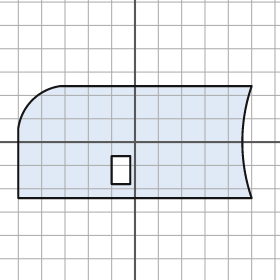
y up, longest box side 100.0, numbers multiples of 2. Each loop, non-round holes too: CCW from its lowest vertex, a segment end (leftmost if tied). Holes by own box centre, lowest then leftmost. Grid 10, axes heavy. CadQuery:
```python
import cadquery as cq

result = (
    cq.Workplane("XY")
    .moveTo(-50.0, -24.0)
    .lineTo(50.0, -24.0)
    .threePointArc((46.0, 0.0), (50.0, 24.0))
    .lineTo(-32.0, 24.0)
    .threePointArc((-44.0, 18.0), (-50.0, 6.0))
    .close()
    .moveTo(-10.0, -18.0)
    .lineTo(-2.0, -18.0)
    .lineTo(-2.0, -6.0)
    .lineTo(-10.0, -6.0)
    .close()
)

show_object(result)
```